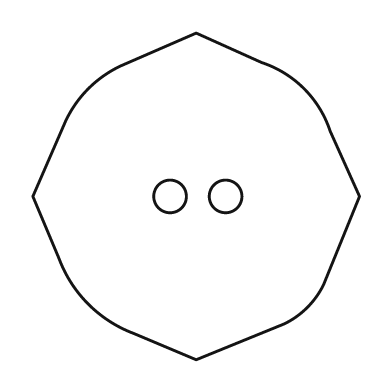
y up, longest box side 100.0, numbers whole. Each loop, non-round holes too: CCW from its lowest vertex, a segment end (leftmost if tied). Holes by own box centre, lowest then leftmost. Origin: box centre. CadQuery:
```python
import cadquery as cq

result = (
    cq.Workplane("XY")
    .moveTo(0.0, -50.0)
    .lineTo(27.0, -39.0)
    .threePointArc((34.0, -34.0), (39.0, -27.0))
    .lineTo(50.0, 0.0)
    .lineTo(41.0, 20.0)
    .threePointArc((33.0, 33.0), (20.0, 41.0))
    .lineTo(0.0, 50.0)
    .lineTo(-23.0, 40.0)
    .threePointArc((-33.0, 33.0), (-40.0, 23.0))
    .lineTo(-50.0, 0.0)
    .lineTo(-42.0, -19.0)
    .threePointArc((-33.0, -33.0), (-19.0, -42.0))
    .close()
    .moveTo(-8.0, 0.0)
    .circle(5.0)
    .moveTo(9.0, 0.0)
    .circle(5.0)
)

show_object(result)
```